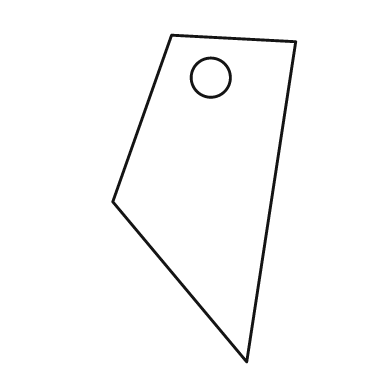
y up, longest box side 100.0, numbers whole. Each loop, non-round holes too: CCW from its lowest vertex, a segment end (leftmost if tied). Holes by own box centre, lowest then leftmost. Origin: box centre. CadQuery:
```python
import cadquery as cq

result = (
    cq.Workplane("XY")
    .moveTo(13.0, -50.0)
    .lineTo(28.0, 48.0)
    .lineTo(-10.0, 50.0)
    .lineTo(-28.0, -1.0)
    .close()
    .moveTo(2.0, 37.0)
    .circle(6.0)
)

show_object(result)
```